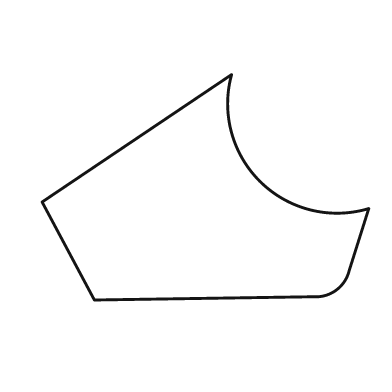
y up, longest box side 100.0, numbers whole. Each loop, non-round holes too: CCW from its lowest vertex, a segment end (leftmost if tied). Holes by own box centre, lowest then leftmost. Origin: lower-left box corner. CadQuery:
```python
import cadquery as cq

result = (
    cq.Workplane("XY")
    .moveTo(16.0, 0.0)
    .lineTo(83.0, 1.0)
    .threePointArc((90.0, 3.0), (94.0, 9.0))
    .lineTo(100.0, 28.0)
    .threePointArc((67.0, 36.0), (58.0, 69.0))
    .lineTo(0.0, 30.0)
    .close()
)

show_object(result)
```